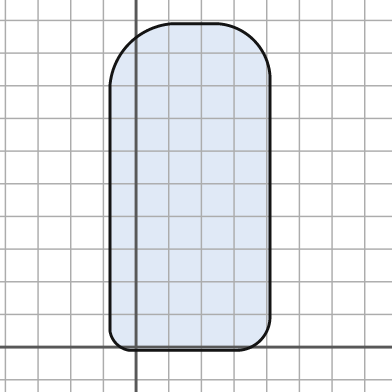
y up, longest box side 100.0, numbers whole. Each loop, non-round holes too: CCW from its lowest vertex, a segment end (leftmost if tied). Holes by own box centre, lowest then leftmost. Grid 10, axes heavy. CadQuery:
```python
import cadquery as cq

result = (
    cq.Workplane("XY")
    .moveTo(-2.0, -1.0)
    .lineTo(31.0, -1.0)
    .threePointArc((38.0, 2.0), (41.0, 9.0))
    .lineTo(41.0, 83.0)
    .threePointArc((36.0, 94.0), (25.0, 99.0))
    .lineTo(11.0, 99.0)
    .threePointArc((-2.0, 93.0), (-8.0, 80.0))
    .lineTo(-8.0, 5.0)
    .threePointArc((-6.0, 1.0), (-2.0, -1.0))
    .close()
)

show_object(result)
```